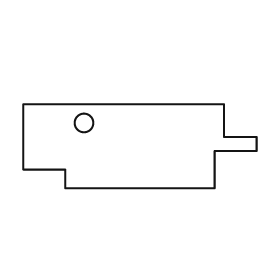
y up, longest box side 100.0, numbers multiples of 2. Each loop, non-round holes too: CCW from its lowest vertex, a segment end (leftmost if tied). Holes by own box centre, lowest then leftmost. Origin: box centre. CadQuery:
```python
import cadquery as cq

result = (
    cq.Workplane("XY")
    .moveTo(-32.0, -18.0)
    .lineTo(32.0, -18.0)
    .lineTo(32.0, -2.0)
    .lineTo(50.0, -2.0)
    .lineTo(50.0, 4.0)
    .lineTo(36.0, 4.0)
    .lineTo(36.0, 18.0)
    .lineTo(-50.0, 18.0)
    .lineTo(-50.0, -10.0)
    .lineTo(-32.0, -10.0)
    .close()
    .moveTo(-24.0, 10.0)
    .circle(4.0)
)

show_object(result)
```